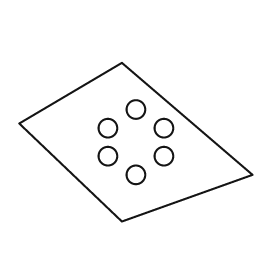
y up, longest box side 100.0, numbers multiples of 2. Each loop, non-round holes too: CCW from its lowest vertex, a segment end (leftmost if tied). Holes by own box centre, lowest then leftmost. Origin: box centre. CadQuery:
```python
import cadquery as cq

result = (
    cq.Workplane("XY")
    .moveTo(-6.0, -34.0)
    .lineTo(50.0, -14.0)
    .lineTo(-6.0, 34.0)
    .lineTo(-50.0, 8.0)
    .close()
    .moveTo(0.0, -14.0)
    .circle(4.0)
    .moveTo(-12.0, -6.0)
    .circle(4.0)
    .moveTo(12.0, -6.0)
    .circle(4.0)
    .moveTo(-12.0, 6.0)
    .circle(4.0)
    .moveTo(12.0, 6.0)
    .circle(4.0)
    .moveTo(0.0, 14.0)
    .circle(4.0)
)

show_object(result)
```